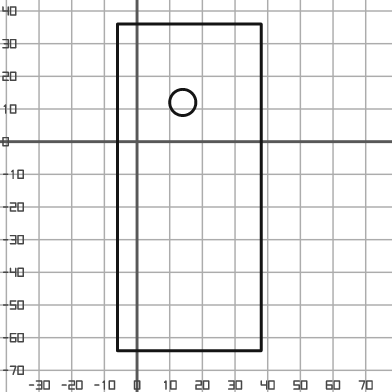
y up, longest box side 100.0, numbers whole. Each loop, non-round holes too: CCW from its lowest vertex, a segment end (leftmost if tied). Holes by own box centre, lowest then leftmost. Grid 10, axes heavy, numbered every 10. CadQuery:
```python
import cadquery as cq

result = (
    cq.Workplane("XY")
    .moveTo(-6.0, -64.0)
    .lineTo(38.0, -64.0)
    .lineTo(38.0, 36.0)
    .lineTo(-6.0, 36.0)
    .close()
    .moveTo(14.0, 12.0)
    .circle(4.0)
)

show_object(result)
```